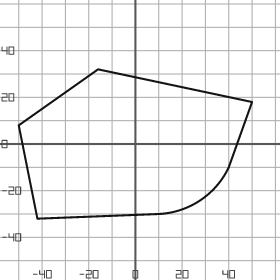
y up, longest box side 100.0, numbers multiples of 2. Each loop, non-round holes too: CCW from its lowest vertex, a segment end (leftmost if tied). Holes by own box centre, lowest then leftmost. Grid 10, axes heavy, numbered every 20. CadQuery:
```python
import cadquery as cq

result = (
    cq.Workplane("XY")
    .moveTo(-42.0, -32.0)
    .lineTo(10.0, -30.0)
    .threePointArc((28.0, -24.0), (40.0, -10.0))
    .lineTo(50.0, 18.0)
    .lineTo(-16.0, 32.0)
    .lineTo(-50.0, 8.0)
    .close()
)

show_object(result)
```